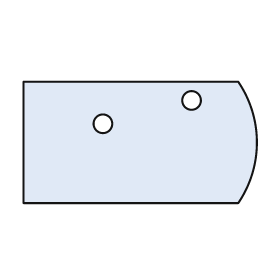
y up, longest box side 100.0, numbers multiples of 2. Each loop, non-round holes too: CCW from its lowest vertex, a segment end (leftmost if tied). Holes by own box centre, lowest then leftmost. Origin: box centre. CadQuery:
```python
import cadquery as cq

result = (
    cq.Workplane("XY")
    .moveTo(-50.0, -26.0)
    .lineTo(42.0, -26.0)
    .threePointArc((50.0, 0.0), (42.0, 26.0))
    .lineTo(-50.0, 26.0)
    .close()
    .moveTo(-16.0, 8.0)
    .circle(4.0)
    .moveTo(22.0, 18.0)
    .circle(4.0)
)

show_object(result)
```